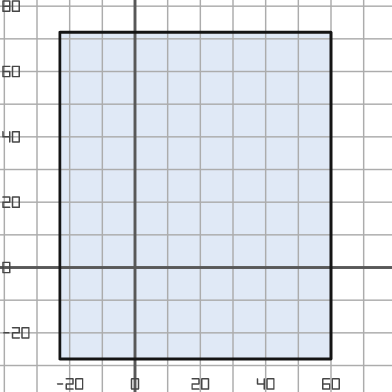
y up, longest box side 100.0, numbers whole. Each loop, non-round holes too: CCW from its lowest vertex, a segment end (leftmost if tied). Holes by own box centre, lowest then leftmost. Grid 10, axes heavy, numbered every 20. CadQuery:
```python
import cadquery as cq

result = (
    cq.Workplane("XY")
    .moveTo(-23.0, -28.0)
    .lineTo(60.0, -28.0)
    .lineTo(60.0, 72.0)
    .lineTo(-23.0, 72.0)
    .close()
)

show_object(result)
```